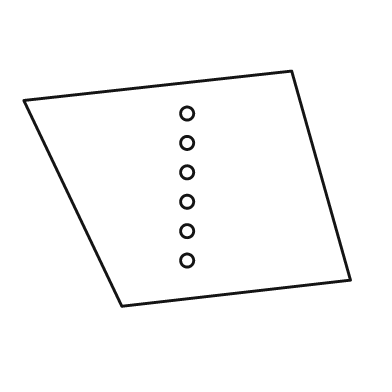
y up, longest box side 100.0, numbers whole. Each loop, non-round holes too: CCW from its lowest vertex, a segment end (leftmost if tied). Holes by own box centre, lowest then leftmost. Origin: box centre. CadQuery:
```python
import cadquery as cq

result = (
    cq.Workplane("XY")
    .moveTo(-20.0, -36.0)
    .lineTo(50.0, -28.0)
    .lineTo(32.0, 36.0)
    .lineTo(-50.0, 27.0)
    .close()
    .moveTo(0.0, -22.0)
    .circle(2.0)
    .moveTo(0.0, -13.0)
    .circle(2.0)
    .moveTo(0.0, -4.0)
    .circle(2.0)
    .moveTo(0.0, 5.0)
    .circle(2.0)
    .moveTo(0.0, 14.0)
    .circle(2.0)
    .moveTo(0.0, 23.0)
    .circle(2.0)
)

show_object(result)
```